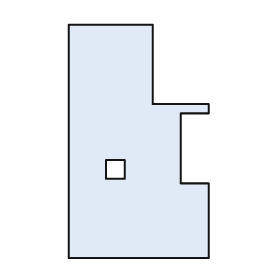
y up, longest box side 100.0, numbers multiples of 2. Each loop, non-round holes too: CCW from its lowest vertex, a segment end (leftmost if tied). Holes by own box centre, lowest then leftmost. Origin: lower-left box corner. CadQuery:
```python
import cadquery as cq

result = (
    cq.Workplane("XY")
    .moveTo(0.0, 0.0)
    .lineTo(60.0, 0.0)
    .lineTo(60.0, 32.0)
    .lineTo(48.0, 32.0)
    .lineTo(48.0, 62.0)
    .lineTo(60.0, 62.0)
    .lineTo(60.0, 66.0)
    .lineTo(36.0, 66.0)
    .lineTo(36.0, 100.0)
    .lineTo(0.0, 100.0)
    .close()
    .moveTo(16.0, 34.0)
    .lineTo(24.0, 34.0)
    .lineTo(24.0, 42.0)
    .lineTo(16.0, 42.0)
    .close()
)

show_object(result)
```